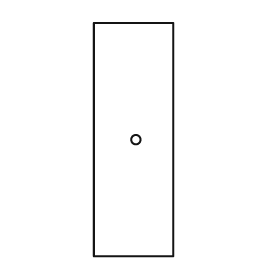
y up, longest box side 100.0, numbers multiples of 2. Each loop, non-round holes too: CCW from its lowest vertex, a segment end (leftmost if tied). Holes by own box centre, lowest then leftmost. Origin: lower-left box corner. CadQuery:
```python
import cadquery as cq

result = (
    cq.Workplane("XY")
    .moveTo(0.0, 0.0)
    .lineTo(34.0, 0.0)
    .lineTo(34.0, 100.0)
    .lineTo(0.0, 100.0)
    .close()
    .moveTo(18.0, 50.0)
    .circle(2.0)
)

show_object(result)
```